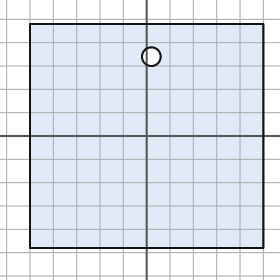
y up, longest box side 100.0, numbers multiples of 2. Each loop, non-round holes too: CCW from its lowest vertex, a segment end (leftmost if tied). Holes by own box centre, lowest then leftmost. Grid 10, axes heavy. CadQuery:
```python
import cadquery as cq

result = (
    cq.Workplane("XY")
    .moveTo(-50.0, -48.0)
    .lineTo(50.0, -48.0)
    .lineTo(50.0, 48.0)
    .lineTo(-50.0, 48.0)
    .close()
    .moveTo(2.0, 34.0)
    .circle(4.0)
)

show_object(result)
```